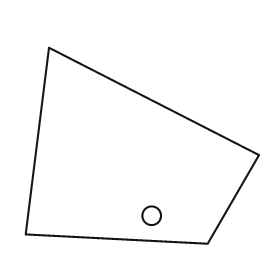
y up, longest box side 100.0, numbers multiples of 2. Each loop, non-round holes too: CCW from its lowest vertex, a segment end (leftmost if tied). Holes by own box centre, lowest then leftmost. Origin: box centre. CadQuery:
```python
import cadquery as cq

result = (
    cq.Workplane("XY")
    .moveTo(28.0, -42.0)
    .lineTo(50.0, -4.0)
    .lineTo(-40.0, 42.0)
    .lineTo(-50.0, -38.0)
    .close()
    .moveTo(4.0, -30.0)
    .circle(4.0)
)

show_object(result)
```